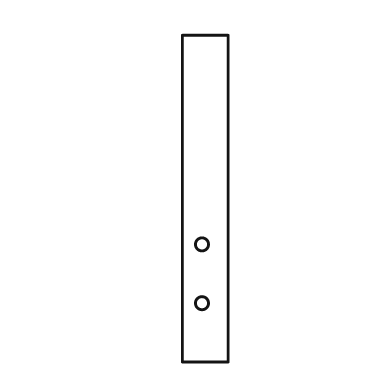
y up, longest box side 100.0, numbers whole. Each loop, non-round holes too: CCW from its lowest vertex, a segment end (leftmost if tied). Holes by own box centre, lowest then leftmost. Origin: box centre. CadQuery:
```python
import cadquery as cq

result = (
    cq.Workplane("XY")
    .moveTo(-7.0, -50.0)
    .lineTo(7.0, -50.0)
    .lineTo(7.0, 50.0)
    .lineTo(-7.0, 50.0)
    .close()
    .moveTo(-1.0, -32.0)
    .circle(2.0)
    .moveTo(-1.0, -14.0)
    .circle(2.0)
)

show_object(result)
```